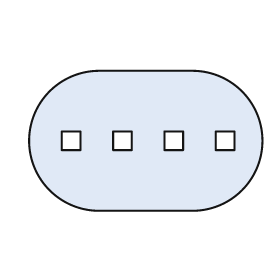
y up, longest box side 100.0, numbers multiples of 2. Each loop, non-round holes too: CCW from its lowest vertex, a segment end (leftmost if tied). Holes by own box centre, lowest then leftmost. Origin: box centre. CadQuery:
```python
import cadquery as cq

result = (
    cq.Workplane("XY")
    .moveTo(-20.0, -30.0)
    .lineTo(20.0, -30.0)
    .threePointArc((50.0, 0.0), (20.0, 30.0))
    .lineTo(-20.0, 30.0)
    .threePointArc((-50.0, 0.0), (-20.0, -30.0))
    .close()
    .moveTo(-36.0, -4.0)
    .lineTo(-28.0, -4.0)
    .lineTo(-28.0, 4.0)
    .lineTo(-36.0, 4.0)
    .close()
    .moveTo(-14.0, -4.0)
    .lineTo(-6.0, -4.0)
    .lineTo(-6.0, 4.0)
    .lineTo(-14.0, 4.0)
    .close()
    .moveTo(8.0, -4.0)
    .lineTo(16.0, -4.0)
    .lineTo(16.0, 4.0)
    .lineTo(8.0, 4.0)
    .close()
    .moveTo(30.0, -4.0)
    .lineTo(38.0, -4.0)
    .lineTo(38.0, 4.0)
    .lineTo(30.0, 4.0)
    .close()
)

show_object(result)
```